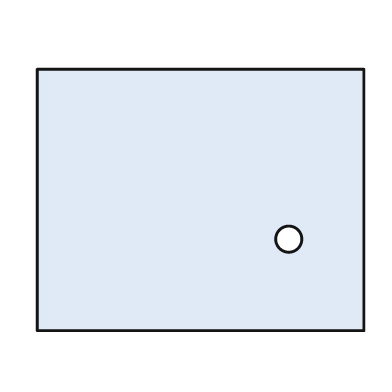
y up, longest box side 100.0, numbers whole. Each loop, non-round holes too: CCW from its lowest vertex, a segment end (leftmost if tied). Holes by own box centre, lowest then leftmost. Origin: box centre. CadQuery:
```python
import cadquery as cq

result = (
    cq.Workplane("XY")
    .moveTo(-50.0, -40.0)
    .lineTo(50.0, -40.0)
    .lineTo(50.0, 40.0)
    .lineTo(-50.0, 40.0)
    .close()
    .moveTo(27.0, -12.0)
    .circle(4.0)
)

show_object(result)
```